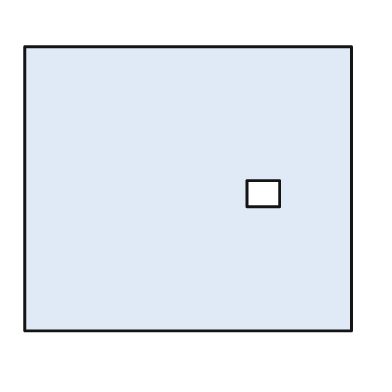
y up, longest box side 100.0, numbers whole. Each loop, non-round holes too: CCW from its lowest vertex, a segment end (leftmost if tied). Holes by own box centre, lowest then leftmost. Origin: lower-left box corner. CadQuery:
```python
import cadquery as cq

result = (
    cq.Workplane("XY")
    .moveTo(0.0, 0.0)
    .lineTo(100.0, 0.0)
    .lineTo(100.0, 87.0)
    .lineTo(0.0, 87.0)
    .close()
    .moveTo(68.0, 38.0)
    .lineTo(78.0, 38.0)
    .lineTo(78.0, 46.0)
    .lineTo(68.0, 46.0)
    .close()
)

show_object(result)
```